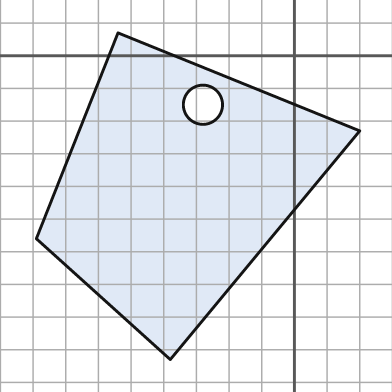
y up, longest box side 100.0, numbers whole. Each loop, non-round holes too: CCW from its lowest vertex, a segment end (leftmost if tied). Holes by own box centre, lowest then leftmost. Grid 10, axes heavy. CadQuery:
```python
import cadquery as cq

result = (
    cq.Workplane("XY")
    .moveTo(-38.0, -93.0)
    .lineTo(20.0, -23.0)
    .lineTo(-54.0, 7.0)
    .lineTo(-79.0, -56.0)
    .close()
    .moveTo(-28.0, -15.0)
    .circle(6.0)
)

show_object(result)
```